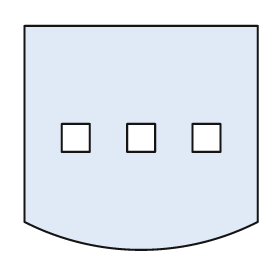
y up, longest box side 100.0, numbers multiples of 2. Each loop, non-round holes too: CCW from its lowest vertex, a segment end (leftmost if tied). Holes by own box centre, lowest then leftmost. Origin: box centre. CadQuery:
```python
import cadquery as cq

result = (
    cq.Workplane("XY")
    .moveTo(-50.0, -36.0)
    .threePointArc((0.0, -48.0), (50.0, -36.0))
    .lineTo(50.0, 48.0)
    .lineTo(-50.0, 48.0)
    .close()
    .moveTo(-34.0, -6.0)
    .lineTo(-22.0, -6.0)
    .lineTo(-22.0, 6.0)
    .lineTo(-34.0, 6.0)
    .close()
    .moveTo(-6.0, -6.0)
    .lineTo(6.0, -6.0)
    .lineTo(6.0, 6.0)
    .lineTo(-6.0, 6.0)
    .close()
    .moveTo(22.0, -6.0)
    .lineTo(34.0, -6.0)
    .lineTo(34.0, 6.0)
    .lineTo(22.0, 6.0)
    .close()
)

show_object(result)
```